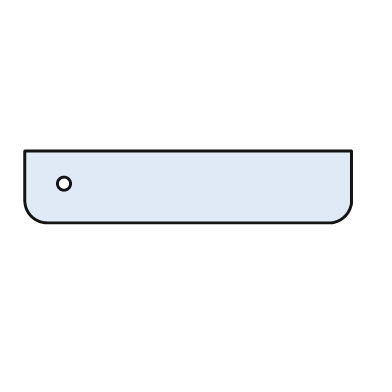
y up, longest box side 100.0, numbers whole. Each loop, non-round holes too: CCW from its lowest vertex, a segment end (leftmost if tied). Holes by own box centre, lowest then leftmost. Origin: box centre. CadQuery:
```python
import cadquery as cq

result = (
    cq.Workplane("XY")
    .moveTo(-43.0, -11.0)
    .lineTo(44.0, -11.0)
    .threePointArc((48.0, -9.0), (50.0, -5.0))
    .lineTo(50.0, 11.0)
    .lineTo(-50.0, 11.0)
    .lineTo(-50.0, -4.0)
    .threePointArc((-48.0, -9.0), (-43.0, -11.0))
    .close()
    .moveTo(-38.0, 1.0)
    .circle(2.0)
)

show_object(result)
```